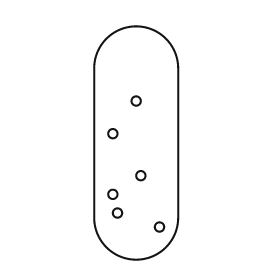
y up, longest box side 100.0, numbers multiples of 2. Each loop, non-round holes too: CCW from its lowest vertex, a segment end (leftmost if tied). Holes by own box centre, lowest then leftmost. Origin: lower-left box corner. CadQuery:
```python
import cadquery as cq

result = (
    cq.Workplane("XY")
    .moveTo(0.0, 18.0)
    .threePointArc((18.0, 0.0), (36.0, 18.0))
    .lineTo(36.0, 82.0)
    .threePointArc((18.0, 100.0), (0.0, 82.0))
    .close()
    .moveTo(28.0, 14.0)
    .circle(2.0)
    .moveTo(10.0, 20.0)
    .circle(2.0)
    .moveTo(8.0, 28.0)
    .circle(2.0)
    .moveTo(20.0, 36.0)
    .circle(2.0)
    .moveTo(8.0, 54.0)
    .circle(2.0)
    .moveTo(18.0, 68.0)
    .circle(2.0)
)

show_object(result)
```